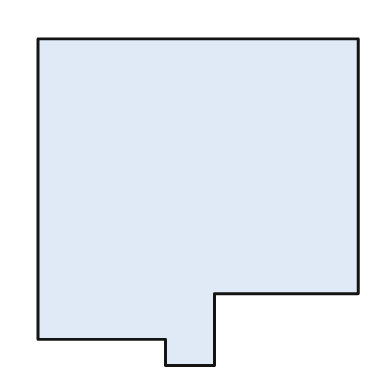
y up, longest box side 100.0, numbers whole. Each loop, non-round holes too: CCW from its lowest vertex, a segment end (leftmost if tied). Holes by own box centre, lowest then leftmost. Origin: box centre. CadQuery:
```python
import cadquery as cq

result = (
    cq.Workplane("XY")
    .moveTo(-10.0, -50.0)
    .lineTo(5.0, -50.0)
    .lineTo(5.0, -28.0)
    .lineTo(49.0, -28.0)
    .lineTo(49.0, 50.0)
    .lineTo(-49.0, 50.0)
    .lineTo(-49.0, -42.0)
    .lineTo(-10.0, -42.0)
    .close()
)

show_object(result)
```